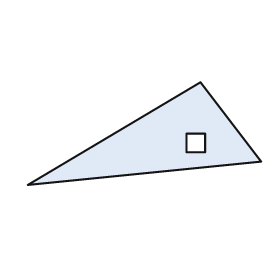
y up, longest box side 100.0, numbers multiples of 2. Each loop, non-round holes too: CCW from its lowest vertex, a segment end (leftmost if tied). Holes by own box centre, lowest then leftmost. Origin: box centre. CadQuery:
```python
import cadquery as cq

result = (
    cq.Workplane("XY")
    .moveTo(-50.0, -22.0)
    .lineTo(50.0, -12.0)
    .lineTo(24.0, 22.0)
    .close()
    .moveTo(18.0, -8.0)
    .lineTo(26.0, -8.0)
    .lineTo(26.0, 0.0)
    .lineTo(18.0, 0.0)
    .close()
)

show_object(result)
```